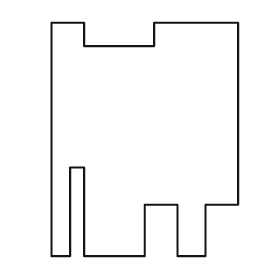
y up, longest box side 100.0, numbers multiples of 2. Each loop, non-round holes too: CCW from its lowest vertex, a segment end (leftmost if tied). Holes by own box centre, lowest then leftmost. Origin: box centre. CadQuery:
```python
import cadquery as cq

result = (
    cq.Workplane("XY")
    .moveTo(-40.0, -50.0)
    .lineTo(-32.0, -50.0)
    .lineTo(-32.0, -12.0)
    .lineTo(-26.0, -12.0)
    .lineTo(-26.0, -50.0)
    .lineTo(0.0, -50.0)
    .lineTo(0.0, -28.0)
    .lineTo(14.0, -28.0)
    .lineTo(14.0, -50.0)
    .lineTo(26.0, -50.0)
    .lineTo(26.0, -28.0)
    .lineTo(40.0, -28.0)
    .lineTo(40.0, 50.0)
    .lineTo(4.0, 50.0)
    .lineTo(4.0, 40.0)
    .lineTo(-26.0, 40.0)
    .lineTo(-26.0, 50.0)
    .lineTo(-40.0, 50.0)
    .close()
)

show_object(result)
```